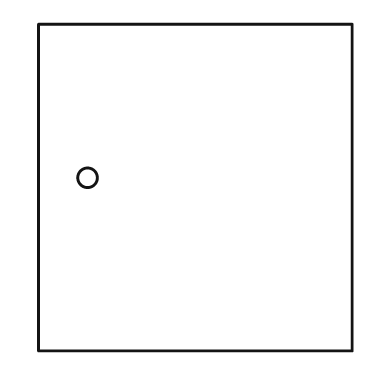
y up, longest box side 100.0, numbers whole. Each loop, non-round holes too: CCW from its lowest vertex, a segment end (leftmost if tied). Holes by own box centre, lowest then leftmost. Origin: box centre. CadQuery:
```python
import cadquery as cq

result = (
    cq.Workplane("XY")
    .moveTo(-48.0, -50.0)
    .lineTo(48.0, -50.0)
    .lineTo(48.0, 50.0)
    .lineTo(-48.0, 50.0)
    .close()
    .moveTo(-33.0, 3.0)
    .circle(3.0)
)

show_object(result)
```